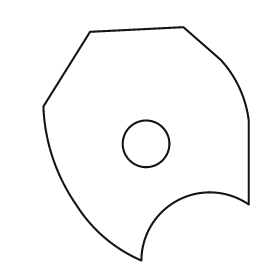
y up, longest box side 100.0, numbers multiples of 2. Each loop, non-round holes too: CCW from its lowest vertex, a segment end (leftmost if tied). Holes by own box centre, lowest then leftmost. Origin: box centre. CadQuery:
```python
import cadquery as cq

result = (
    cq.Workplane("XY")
    .moveTo(-2.0, -50.0)
    .threePointArc((14.0, -24.0), (44.0, -26.0))
    .lineTo(44.0, 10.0)
    .threePointArc((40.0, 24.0), (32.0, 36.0))
    .lineTo(16.0, 50.0)
    .lineTo(-24.0, 48.0)
    .lineTo(-44.0, 16.0)
    .threePointArc((-40.0, -6.0), (-30.0, -26.0))
    .threePointArc((-18.0, -40.0), (-2.0, -50.0))
    .close()
    .moveTo(0.0, 0.0)
    .circle(10.0)
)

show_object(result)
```